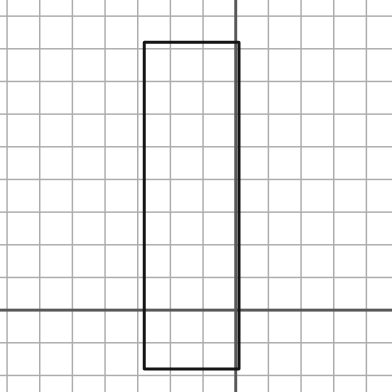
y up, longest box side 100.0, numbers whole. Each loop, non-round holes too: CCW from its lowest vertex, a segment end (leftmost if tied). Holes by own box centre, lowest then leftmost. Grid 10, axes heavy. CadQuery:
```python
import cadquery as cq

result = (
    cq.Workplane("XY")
    .moveTo(-28.0, -18.0)
    .lineTo(1.0, -18.0)
    .lineTo(1.0, 82.0)
    .lineTo(-28.0, 82.0)
    .close()
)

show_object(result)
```